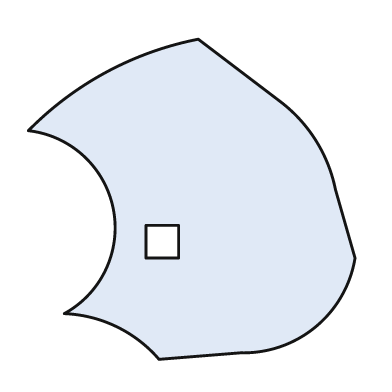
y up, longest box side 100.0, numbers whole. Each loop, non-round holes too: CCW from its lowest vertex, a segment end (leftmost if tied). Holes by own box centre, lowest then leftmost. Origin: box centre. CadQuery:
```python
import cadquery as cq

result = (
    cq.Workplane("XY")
    .moveTo(-10.0, -49.0)
    .lineTo(15.0, -47.0)
    .threePointArc((38.0, -39.0), (50.0, -18.0))
    .lineTo(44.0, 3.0)
    .threePointArc((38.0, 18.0), (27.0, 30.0))
    .lineTo(2.0, 49.0)
    .threePointArc((-26.0, 39.0), (-50.0, 21.0))
    .threePointArc((-24.0, -3.0), (-39.0, -35.0))
    .threePointArc((-23.0, -39.0), (-10.0, -49.0))
    .close()
    .moveTo(-14.0, -18.0)
    .lineTo(-4.0, -18.0)
    .lineTo(-4.0, -8.0)
    .lineTo(-14.0, -8.0)
    .close()
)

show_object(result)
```